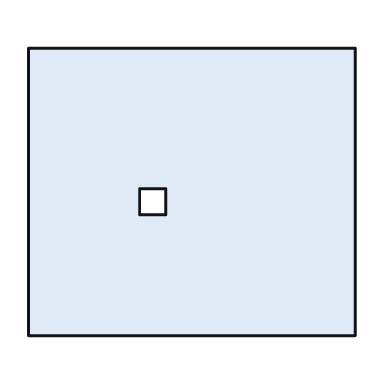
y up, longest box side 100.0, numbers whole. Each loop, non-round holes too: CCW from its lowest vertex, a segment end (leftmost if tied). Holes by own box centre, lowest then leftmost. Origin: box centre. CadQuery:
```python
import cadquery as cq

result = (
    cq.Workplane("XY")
    .moveTo(-50.0, -44.0)
    .lineTo(50.0, -44.0)
    .lineTo(50.0, 44.0)
    .lineTo(-50.0, 44.0)
    .close()
    .moveTo(-16.0, -7.0)
    .lineTo(-8.0, -7.0)
    .lineTo(-8.0, 1.0)
    .lineTo(-16.0, 1.0)
    .close()
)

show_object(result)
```